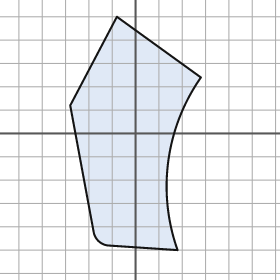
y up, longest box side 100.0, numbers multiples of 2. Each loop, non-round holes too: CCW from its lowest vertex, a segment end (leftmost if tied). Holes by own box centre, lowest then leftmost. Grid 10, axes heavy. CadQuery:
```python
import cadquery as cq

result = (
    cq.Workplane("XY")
    .moveTo(18.0, -50.0)
    .threePointArc((14.0, -12.0), (28.0, 24.0))
    .lineTo(-8.0, 50.0)
    .lineTo(-28.0, 12.0)
    .lineTo(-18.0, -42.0)
    .threePointArc((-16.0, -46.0), (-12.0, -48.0))
    .close()
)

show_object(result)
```